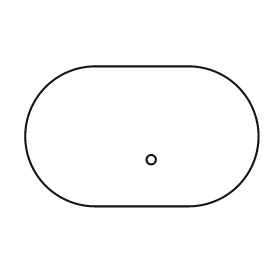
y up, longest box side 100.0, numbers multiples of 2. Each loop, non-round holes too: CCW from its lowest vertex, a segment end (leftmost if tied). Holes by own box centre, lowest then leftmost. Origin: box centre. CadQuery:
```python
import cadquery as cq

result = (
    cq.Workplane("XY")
    .moveTo(-20.0, -30.0)
    .lineTo(20.0, -30.0)
    .threePointArc((50.0, 0.0), (20.0, 30.0))
    .lineTo(-20.0, 30.0)
    .threePointArc((-50.0, 0.0), (-20.0, -30.0))
    .close()
    .moveTo(4.0, -10.0)
    .circle(2.0)
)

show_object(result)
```